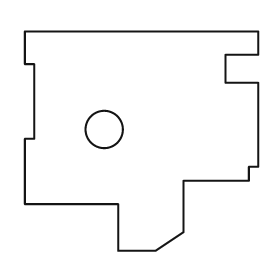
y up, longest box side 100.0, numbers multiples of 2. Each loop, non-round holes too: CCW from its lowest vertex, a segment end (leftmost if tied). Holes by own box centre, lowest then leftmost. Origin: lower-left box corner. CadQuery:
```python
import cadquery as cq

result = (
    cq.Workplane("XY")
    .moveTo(40.0, 0.0)
    .lineTo(56.0, 0.0)
    .lineTo(68.0, 8.0)
    .lineTo(68.0, 30.0)
    .lineTo(96.0, 30.0)
    .lineTo(96.0, 36.0)
    .lineTo(100.0, 36.0)
    .lineTo(100.0, 72.0)
    .lineTo(86.0, 72.0)
    .lineTo(86.0, 84.0)
    .lineTo(100.0, 84.0)
    .lineTo(100.0, 94.0)
    .lineTo(0.0, 94.0)
    .lineTo(0.0, 80.0)
    .lineTo(4.0, 80.0)
    .lineTo(4.0, 48.0)
    .lineTo(0.0, 48.0)
    .lineTo(0.0, 20.0)
    .lineTo(40.0, 20.0)
    .close()
    .moveTo(34.0, 52.0)
    .circle(8.0)
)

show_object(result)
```